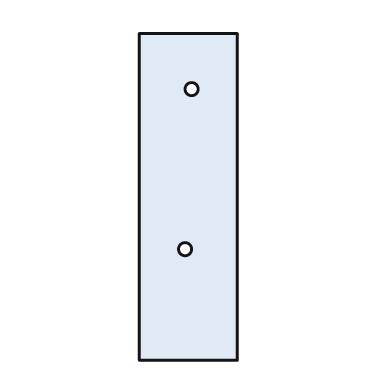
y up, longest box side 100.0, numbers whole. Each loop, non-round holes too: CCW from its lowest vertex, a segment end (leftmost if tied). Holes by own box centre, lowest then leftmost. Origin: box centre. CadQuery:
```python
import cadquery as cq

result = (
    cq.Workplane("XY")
    .moveTo(-15.0, -50.0)
    .lineTo(15.0, -50.0)
    .lineTo(15.0, 50.0)
    .lineTo(-15.0, 50.0)
    .close()
    .moveTo(-1.0, -16.0)
    .circle(2.0)
    .moveTo(1.0, 33.0)
    .circle(2.0)
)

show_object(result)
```